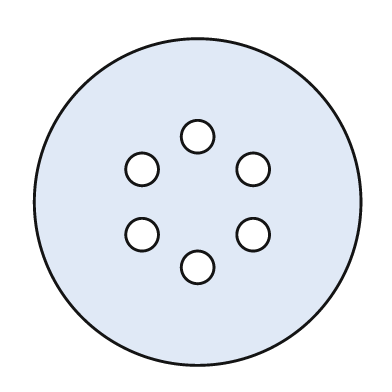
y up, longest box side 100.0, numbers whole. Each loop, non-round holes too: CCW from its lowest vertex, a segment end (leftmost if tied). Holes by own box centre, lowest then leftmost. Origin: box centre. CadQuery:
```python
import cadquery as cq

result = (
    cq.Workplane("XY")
    .moveTo(0.0, 0.0)
    .circle(50.0)
    .moveTo(0.0, -20.0)
    .circle(5.0)
    .moveTo(-17.0, -10.0)
    .circle(5.0)
    .moveTo(17.0, -10.0)
    .circle(5.0)
    .moveTo(-17.0, 10.0)
    .circle(5.0)
    .moveTo(17.0, 10.0)
    .circle(5.0)
    .moveTo(0.0, 20.0)
    .circle(5.0)
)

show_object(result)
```